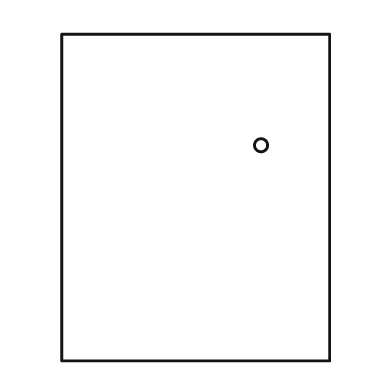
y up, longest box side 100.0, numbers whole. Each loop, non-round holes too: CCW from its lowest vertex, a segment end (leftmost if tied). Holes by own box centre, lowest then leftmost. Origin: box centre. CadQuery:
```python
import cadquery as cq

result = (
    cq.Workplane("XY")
    .moveTo(-41.0, -50.0)
    .lineTo(41.0, -50.0)
    .lineTo(41.0, 50.0)
    .lineTo(-41.0, 50.0)
    .close()
    .moveTo(20.0, 16.0)
    .circle(2.0)
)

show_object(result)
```